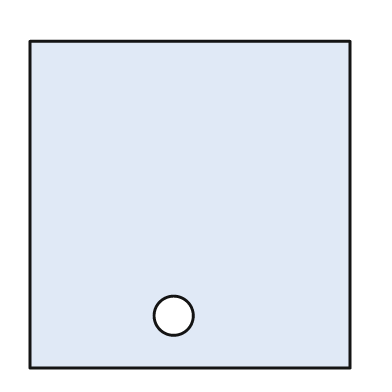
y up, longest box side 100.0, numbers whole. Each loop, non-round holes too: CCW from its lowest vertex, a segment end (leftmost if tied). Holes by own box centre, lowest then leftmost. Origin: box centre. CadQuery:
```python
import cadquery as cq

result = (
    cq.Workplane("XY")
    .moveTo(-49.0, -50.0)
    .lineTo(49.0, -50.0)
    .lineTo(49.0, 50.0)
    .lineTo(-49.0, 50.0)
    .close()
    .moveTo(-5.0, -34.0)
    .circle(6.0)
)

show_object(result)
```